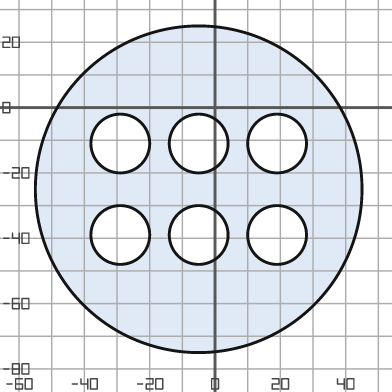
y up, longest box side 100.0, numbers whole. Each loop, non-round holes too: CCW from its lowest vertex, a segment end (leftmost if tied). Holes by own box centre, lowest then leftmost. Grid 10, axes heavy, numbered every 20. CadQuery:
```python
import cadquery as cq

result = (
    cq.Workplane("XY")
    .moveTo(-5.0, -25.0)
    .circle(50.0)
    .moveTo(-29.0, -39.0)
    .circle(9.0)
    .moveTo(-5.0, -39.0)
    .circle(9.0)
    .moveTo(19.0, -39.0)
    .circle(9.0)
    .moveTo(-29.0, -11.0)
    .circle(9.0)
    .moveTo(-5.0, -11.0)
    .circle(9.0)
    .moveTo(19.0, -11.0)
    .circle(9.0)
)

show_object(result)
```